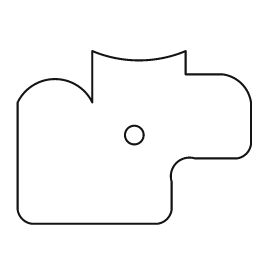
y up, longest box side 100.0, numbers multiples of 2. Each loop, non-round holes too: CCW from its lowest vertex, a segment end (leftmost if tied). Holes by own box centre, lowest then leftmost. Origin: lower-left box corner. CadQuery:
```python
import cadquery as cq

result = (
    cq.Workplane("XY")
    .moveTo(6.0, 0.0)
    .lineTo(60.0, 0.0)
    .threePointArc((64.0, 2.0), (66.0, 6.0))
    .lineTo(66.0, 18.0)
    .threePointArc((68.0, 26.0), (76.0, 28.0))
    .lineTo(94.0, 28.0)
    .threePointArc((98.0, 30.0), (100.0, 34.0))
    .lineTo(100.0, 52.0)
    .threePointArc((96.0, 60.0), (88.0, 64.0))
    .lineTo(72.0, 64.0)
    .lineTo(72.0, 74.0)
    .threePointArc((52.0, 70.0), (32.0, 74.0))
    .lineTo(32.0, 52.0)
    .threePointArc((16.0, 62.0), (0.0, 52.0))
    .lineTo(0.0, 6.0)
    .threePointArc((2.0, 2.0), (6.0, 0.0))
    .close()
    .moveTo(50.0, 38.0)
    .circle(4.0)
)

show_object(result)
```